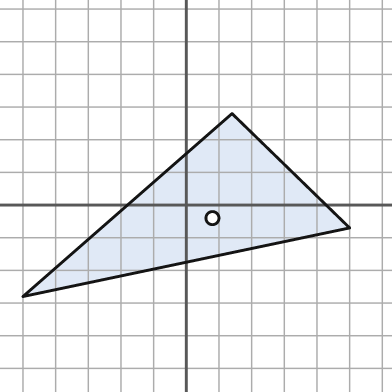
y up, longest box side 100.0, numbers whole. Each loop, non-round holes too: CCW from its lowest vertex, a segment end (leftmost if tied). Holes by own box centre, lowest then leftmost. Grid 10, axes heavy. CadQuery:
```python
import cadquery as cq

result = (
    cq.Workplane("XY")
    .moveTo(-50.0, -28.0)
    .lineTo(50.0, -7.0)
    .lineTo(14.0, 28.0)
    .close()
    .moveTo(8.0, -4.0)
    .circle(2.0)
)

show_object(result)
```